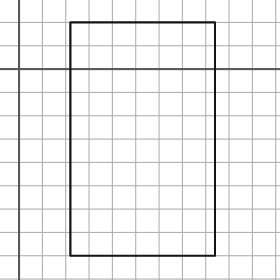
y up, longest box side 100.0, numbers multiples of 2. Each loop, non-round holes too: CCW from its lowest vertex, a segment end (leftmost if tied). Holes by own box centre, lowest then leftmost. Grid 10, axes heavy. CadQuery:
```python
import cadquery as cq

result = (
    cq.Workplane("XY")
    .moveTo(22.0, -80.0)
    .lineTo(84.0, -80.0)
    .lineTo(84.0, 20.0)
    .lineTo(22.0, 20.0)
    .close()
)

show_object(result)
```